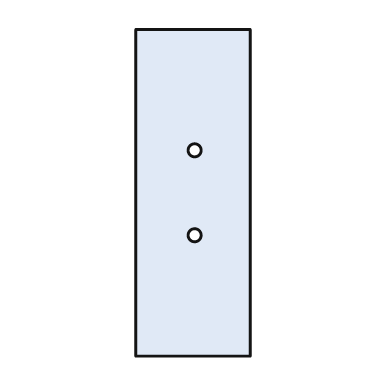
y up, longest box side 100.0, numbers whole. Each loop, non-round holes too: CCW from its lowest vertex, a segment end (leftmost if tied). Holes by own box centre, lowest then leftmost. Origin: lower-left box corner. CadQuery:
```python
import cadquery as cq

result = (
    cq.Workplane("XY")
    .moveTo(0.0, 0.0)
    .lineTo(35.0, 0.0)
    .lineTo(35.0, 100.0)
    .lineTo(0.0, 100.0)
    .close()
    .moveTo(18.0, 37.0)
    .circle(2.0)
    .moveTo(18.0, 63.0)
    .circle(2.0)
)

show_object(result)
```